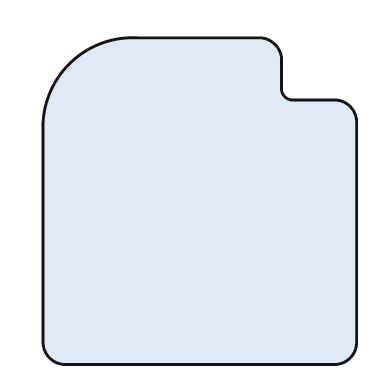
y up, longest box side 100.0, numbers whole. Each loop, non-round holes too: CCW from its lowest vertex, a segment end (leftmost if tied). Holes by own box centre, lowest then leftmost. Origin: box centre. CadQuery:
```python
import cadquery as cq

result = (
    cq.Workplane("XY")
    .moveTo(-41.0, -50.0)
    .lineTo(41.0, -50.0)
    .threePointArc((46.0, -48.0), (48.0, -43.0))
    .lineTo(48.0, 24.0)
    .threePointArc((46.0, 29.0), (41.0, 31.0))
    .lineTo(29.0, 31.0)
    .threePointArc((26.0, 32.0), (25.0, 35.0))
    .lineTo(25.0, 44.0)
    .threePointArc((23.0, 48.0), (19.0, 50.0))
    .lineTo(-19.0, 50.0)
    .threePointArc((-40.0, 42.0), (-48.0, 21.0))
    .lineTo(-48.0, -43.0)
    .threePointArc((-46.0, -48.0), (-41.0, -50.0))
    .close()
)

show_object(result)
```